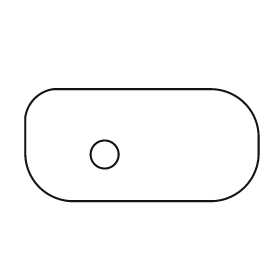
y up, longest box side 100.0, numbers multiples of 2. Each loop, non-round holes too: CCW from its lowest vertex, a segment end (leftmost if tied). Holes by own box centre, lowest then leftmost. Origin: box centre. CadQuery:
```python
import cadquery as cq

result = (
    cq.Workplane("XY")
    .moveTo(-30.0, -24.0)
    .lineTo(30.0, -24.0)
    .threePointArc((44.0, -18.0), (50.0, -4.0))
    .lineTo(50.0, 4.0)
    .threePointArc((44.0, 18.0), (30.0, 24.0))
    .lineTo(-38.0, 24.0)
    .threePointArc((-46.0, 20.0), (-50.0, 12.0))
    .lineTo(-50.0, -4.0)
    .threePointArc((-44.0, -18.0), (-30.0, -24.0))
    .close()
    .moveTo(-16.0, -4.0)
    .circle(6.0)
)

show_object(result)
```